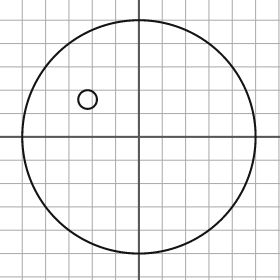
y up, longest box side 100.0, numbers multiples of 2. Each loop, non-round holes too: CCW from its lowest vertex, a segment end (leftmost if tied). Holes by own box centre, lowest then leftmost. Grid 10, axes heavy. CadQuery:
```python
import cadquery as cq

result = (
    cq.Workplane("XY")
    .moveTo(0.0, 0.0)
    .circle(50.0)
    .moveTo(-22.0, 16.0)
    .circle(4.0)
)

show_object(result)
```